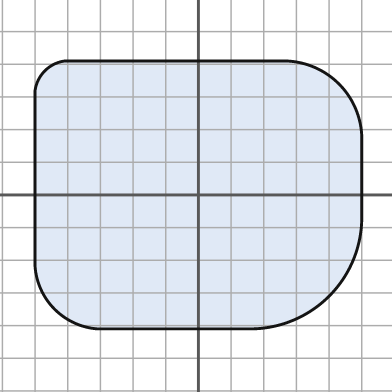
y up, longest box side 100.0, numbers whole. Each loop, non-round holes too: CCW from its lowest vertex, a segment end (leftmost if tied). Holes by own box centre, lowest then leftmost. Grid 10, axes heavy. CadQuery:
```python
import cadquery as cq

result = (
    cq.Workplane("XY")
    .moveTo(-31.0, -41.0)
    .lineTo(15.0, -41.0)
    .threePointArc((40.0, -31.0), (50.0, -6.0))
    .lineTo(50.0, 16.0)
    .threePointArc((43.0, 34.0), (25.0, 41.0))
    .lineTo(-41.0, 41.0)
    .threePointArc((-47.0, 38.0), (-50.0, 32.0))
    .lineTo(-50.0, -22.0)
    .threePointArc((-44.0, -35.0), (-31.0, -41.0))
    .close()
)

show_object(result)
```